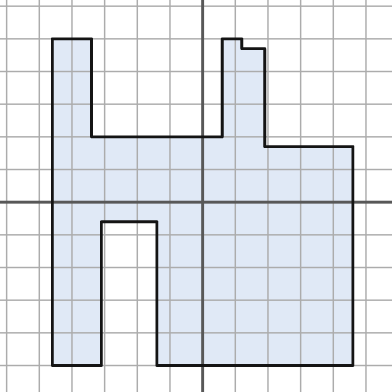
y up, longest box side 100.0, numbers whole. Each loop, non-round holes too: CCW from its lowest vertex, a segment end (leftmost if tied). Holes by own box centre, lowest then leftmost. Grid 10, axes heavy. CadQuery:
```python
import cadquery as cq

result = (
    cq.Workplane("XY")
    .moveTo(-46.0, -50.0)
    .lineTo(-31.0, -50.0)
    .lineTo(-31.0, -6.0)
    .lineTo(-14.0, -6.0)
    .lineTo(-14.0, -50.0)
    .lineTo(46.0, -50.0)
    .lineTo(46.0, 17.0)
    .lineTo(19.0, 17.0)
    .lineTo(19.0, 47.0)
    .lineTo(12.0, 47.0)
    .lineTo(12.0, 50.0)
    .lineTo(6.0, 50.0)
    .lineTo(6.0, 20.0)
    .lineTo(-34.0, 20.0)
    .lineTo(-34.0, 50.0)
    .lineTo(-46.0, 50.0)
    .close()
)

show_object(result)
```